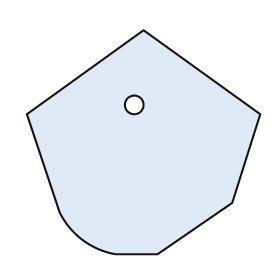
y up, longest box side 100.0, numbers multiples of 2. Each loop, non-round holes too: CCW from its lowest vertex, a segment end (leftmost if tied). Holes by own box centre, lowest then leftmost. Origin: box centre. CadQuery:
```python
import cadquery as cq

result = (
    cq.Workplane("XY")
    .moveTo(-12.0, -48.0)
    .lineTo(6.0, -48.0)
    .lineTo(38.0, -26.0)
    .lineTo(50.0, 12.0)
    .lineTo(0.0, 48.0)
    .lineTo(-50.0, 12.0)
    .lineTo(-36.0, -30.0)
    .threePointArc((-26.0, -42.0), (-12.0, -48.0))
    .close()
    .moveTo(-4.0, 16.0)
    .circle(4.0)
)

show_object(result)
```